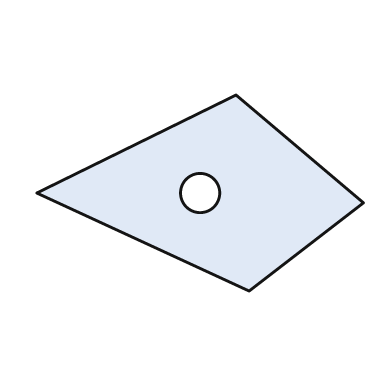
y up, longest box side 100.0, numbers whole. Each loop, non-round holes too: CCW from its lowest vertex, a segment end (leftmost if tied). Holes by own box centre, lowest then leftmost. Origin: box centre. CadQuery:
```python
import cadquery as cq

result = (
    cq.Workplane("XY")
    .moveTo(15.0, -30.0)
    .lineTo(50.0, -3.0)
    .lineTo(11.0, 30.0)
    .lineTo(-50.0, 0.0)
    .close()
    .moveTo(0.0, 0.0)
    .circle(6.0)
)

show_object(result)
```